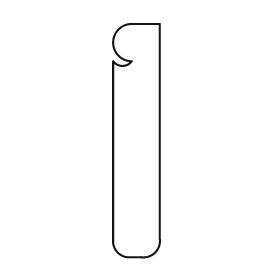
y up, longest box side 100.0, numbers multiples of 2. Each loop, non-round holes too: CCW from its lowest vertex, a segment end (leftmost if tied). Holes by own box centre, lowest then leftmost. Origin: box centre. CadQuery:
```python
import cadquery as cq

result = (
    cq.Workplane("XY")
    .moveTo(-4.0, -50.0)
    .lineTo(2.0, -50.0)
    .threePointArc((8.0, -48.0), (10.0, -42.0))
    .lineTo(10.0, 50.0)
    .lineTo(-2.0, 50.0)
    .threePointArc((-10.0, 42.0), (-2.0, 34.0))
    .threePointArc((-6.0, 32.0), (-10.0, 34.0))
    .lineTo(-10.0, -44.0)
    .threePointArc((-8.0, -48.0), (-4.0, -50.0))
    .close()
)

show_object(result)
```